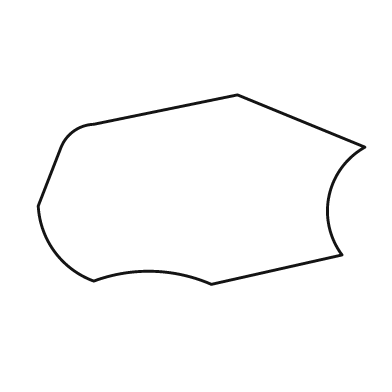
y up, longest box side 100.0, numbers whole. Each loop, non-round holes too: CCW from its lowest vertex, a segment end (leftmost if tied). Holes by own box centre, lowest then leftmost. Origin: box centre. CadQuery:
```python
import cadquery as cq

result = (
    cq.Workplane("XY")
    .moveTo(3.0, -29.0)
    .lineTo(43.0, -20.0)
    .threePointArc((39.0, -2.0), (50.0, 13.0))
    .lineTo(11.0, 29.0)
    .lineTo(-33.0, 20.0)
    .threePointArc((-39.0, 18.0), (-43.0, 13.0))
    .lineTo(-50.0, -5.0)
    .threePointArc((-45.0, -19.0), (-33.0, -28.0))
    .threePointArc((-15.0, -25.0), (3.0, -29.0))
    .close()
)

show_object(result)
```